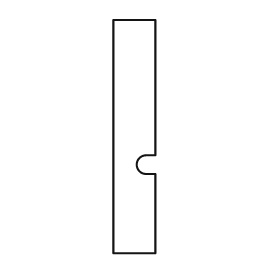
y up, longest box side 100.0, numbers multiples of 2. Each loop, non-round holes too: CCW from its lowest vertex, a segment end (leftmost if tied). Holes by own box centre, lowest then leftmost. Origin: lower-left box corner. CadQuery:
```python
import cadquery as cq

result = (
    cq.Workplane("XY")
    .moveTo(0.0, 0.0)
    .lineTo(18.0, 0.0)
    .lineTo(18.0, 34.0)
    .lineTo(14.0, 34.0)
    .threePointArc((10.0, 38.0), (14.0, 42.0))
    .lineTo(18.0, 42.0)
    .lineTo(18.0, 100.0)
    .lineTo(0.0, 100.0)
    .close()
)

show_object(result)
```